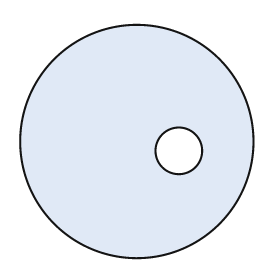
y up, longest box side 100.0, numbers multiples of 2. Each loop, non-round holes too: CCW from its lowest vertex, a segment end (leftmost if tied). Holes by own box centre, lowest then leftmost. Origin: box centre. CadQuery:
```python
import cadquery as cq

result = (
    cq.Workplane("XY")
    .moveTo(0.0, 0.0)
    .circle(50.0)
    .moveTo(18.0, -4.0)
    .circle(10.0)
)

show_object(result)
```